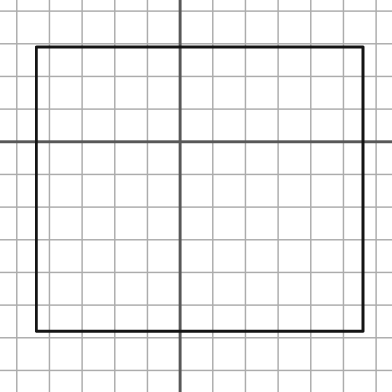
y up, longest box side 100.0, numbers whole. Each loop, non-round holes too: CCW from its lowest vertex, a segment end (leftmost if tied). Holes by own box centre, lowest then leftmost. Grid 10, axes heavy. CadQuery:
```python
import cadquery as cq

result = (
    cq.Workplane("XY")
    .moveTo(-44.0, -58.0)
    .lineTo(56.0, -58.0)
    .lineTo(56.0, 29.0)
    .lineTo(-44.0, 29.0)
    .close()
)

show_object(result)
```